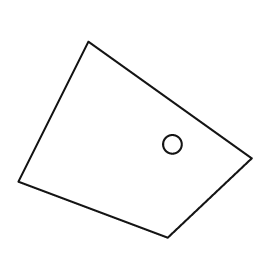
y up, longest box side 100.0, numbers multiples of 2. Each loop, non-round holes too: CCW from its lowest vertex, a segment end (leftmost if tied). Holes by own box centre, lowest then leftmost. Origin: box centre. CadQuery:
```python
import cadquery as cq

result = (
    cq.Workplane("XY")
    .moveTo(14.0, -42.0)
    .lineTo(50.0, -8.0)
    .lineTo(-20.0, 42.0)
    .lineTo(-50.0, -18.0)
    .close()
    .moveTo(16.0, -2.0)
    .circle(4.0)
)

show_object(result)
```